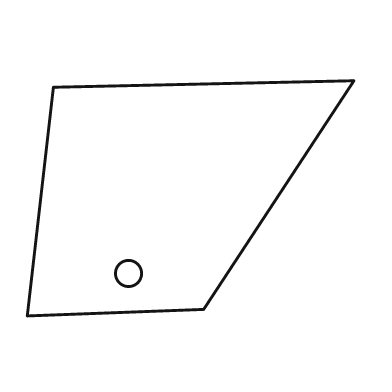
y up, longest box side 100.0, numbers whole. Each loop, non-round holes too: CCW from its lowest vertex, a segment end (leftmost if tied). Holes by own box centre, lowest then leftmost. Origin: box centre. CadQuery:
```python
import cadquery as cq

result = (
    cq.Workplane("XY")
    .moveTo(-50.0, -36.0)
    .lineTo(4.0, -34.0)
    .lineTo(50.0, 36.0)
    .lineTo(-42.0, 34.0)
    .close()
    .moveTo(-19.0, -23.0)
    .circle(4.0)
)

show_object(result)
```